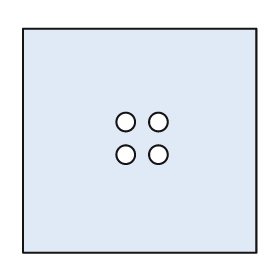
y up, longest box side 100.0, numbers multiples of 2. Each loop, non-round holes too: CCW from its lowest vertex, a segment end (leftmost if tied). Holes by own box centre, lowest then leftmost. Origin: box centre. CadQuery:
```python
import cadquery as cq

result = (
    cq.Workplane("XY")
    .moveTo(-50.0, -48.0)
    .lineTo(50.0, -48.0)
    .lineTo(50.0, 48.0)
    .lineTo(-50.0, 48.0)
    .close()
    .moveTo(-6.0, -6.0)
    .circle(4.0)
    .moveTo(8.0, -6.0)
    .circle(4.0)
    .moveTo(-6.0, 8.0)
    .circle(4.0)
    .moveTo(8.0, 8.0)
    .circle(4.0)
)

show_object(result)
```